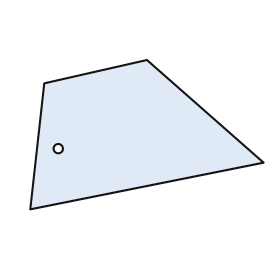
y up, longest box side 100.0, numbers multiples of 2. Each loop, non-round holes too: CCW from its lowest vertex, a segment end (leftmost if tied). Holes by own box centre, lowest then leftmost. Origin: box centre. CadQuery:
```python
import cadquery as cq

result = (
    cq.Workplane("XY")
    .moveTo(-50.0, -32.0)
    .lineTo(50.0, -12.0)
    .lineTo(0.0, 32.0)
    .lineTo(-44.0, 22.0)
    .close()
    .moveTo(-38.0, -6.0)
    .circle(2.0)
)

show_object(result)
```